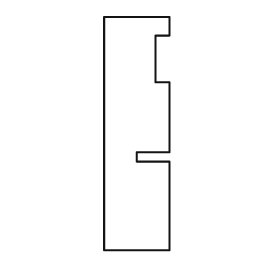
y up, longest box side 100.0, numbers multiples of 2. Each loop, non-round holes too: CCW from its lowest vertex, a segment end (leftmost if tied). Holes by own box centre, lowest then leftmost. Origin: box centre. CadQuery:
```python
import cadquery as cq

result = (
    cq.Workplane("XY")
    .moveTo(-14.0, -50.0)
    .lineTo(14.0, -50.0)
    .lineTo(14.0, -12.0)
    .lineTo(0.0, -12.0)
    .lineTo(0.0, -8.0)
    .lineTo(14.0, -8.0)
    .lineTo(14.0, 22.0)
    .lineTo(8.0, 22.0)
    .lineTo(8.0, 42.0)
    .lineTo(14.0, 42.0)
    .lineTo(14.0, 50.0)
    .lineTo(-14.0, 50.0)
    .close()
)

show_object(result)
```